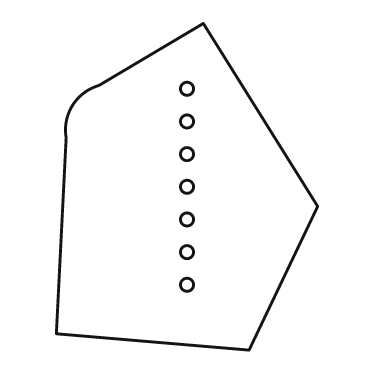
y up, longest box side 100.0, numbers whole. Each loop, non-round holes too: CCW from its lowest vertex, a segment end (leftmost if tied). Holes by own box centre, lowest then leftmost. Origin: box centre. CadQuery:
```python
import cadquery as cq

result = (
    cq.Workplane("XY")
    .moveTo(19.0, -50.0)
    .lineTo(40.0, -6.0)
    .lineTo(5.0, 50.0)
    .lineTo(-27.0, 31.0)
    .threePointArc((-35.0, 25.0), (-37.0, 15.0))
    .lineTo(-40.0, -45.0)
    .close()
    .moveTo(0.0, -30.0)
    .circle(2.0)
    .moveTo(0.0, -20.0)
    .circle(2.0)
    .moveTo(0.0, -10.0)
    .circle(2.0)
    .moveTo(0.0, 0.0)
    .circle(2.0)
    .moveTo(0.0, 10.0)
    .circle(2.0)
    .moveTo(0.0, 20.0)
    .circle(2.0)
    .moveTo(0.0, 30.0)
    .circle(2.0)
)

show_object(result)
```